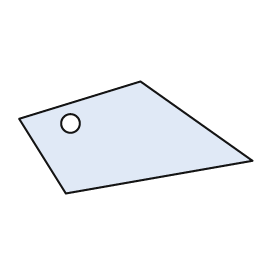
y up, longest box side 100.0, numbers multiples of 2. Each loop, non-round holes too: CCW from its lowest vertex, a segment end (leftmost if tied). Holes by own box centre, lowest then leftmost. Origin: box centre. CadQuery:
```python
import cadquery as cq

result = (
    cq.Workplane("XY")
    .moveTo(-30.0, -24.0)
    .lineTo(50.0, -10.0)
    .lineTo(2.0, 24.0)
    .lineTo(-50.0, 8.0)
    .close()
    .moveTo(-28.0, 6.0)
    .circle(4.0)
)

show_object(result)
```